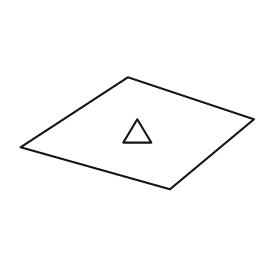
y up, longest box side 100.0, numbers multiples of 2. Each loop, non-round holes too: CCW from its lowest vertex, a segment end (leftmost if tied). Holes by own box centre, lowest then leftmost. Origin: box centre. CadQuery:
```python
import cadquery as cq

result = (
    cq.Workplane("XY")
    .moveTo(14.0, -24.0)
    .lineTo(50.0, 6.0)
    .lineTo(-4.0, 24.0)
    .lineTo(-50.0, -6.0)
    .close()
    .moveTo(-6.0, -4.0)
    .lineTo(6.0, -4.0)
    .lineTo(0.0, 6.0)
    .close()
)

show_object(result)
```